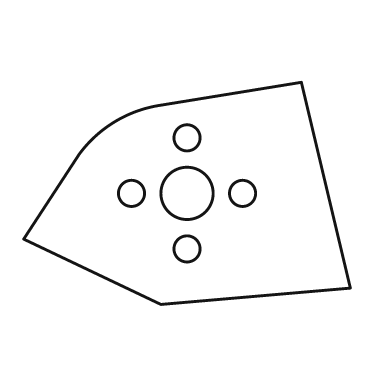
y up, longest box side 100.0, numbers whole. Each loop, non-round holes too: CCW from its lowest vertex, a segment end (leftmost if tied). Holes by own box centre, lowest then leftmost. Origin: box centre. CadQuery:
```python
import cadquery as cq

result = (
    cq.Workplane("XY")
    .moveTo(-8.0, -34.0)
    .lineTo(50.0, -29.0)
    .lineTo(35.0, 34.0)
    .lineTo(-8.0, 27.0)
    .threePointArc((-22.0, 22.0), (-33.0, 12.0))
    .lineTo(-50.0, -14.0)
    .close()
    .moveTo(0.0, -17.0)
    .circle(4.0)
    .moveTo(-17.0, 0.0)
    .circle(4.0)
    .moveTo(0.0, 0.0)
    .circle(8.0)
    .moveTo(17.0, 0.0)
    .circle(4.0)
    .moveTo(0.0, 17.0)
    .circle(4.0)
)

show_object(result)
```